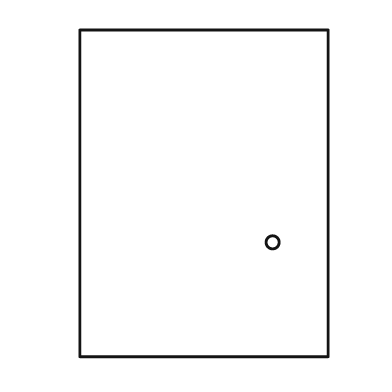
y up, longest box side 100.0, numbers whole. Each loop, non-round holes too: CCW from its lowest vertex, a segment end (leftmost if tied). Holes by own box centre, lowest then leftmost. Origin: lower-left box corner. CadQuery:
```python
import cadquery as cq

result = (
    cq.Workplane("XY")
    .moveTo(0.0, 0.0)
    .lineTo(76.0, 0.0)
    .lineTo(76.0, 100.0)
    .lineTo(0.0, 100.0)
    .close()
    .moveTo(59.0, 35.0)
    .circle(2.0)
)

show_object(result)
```